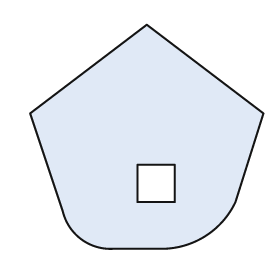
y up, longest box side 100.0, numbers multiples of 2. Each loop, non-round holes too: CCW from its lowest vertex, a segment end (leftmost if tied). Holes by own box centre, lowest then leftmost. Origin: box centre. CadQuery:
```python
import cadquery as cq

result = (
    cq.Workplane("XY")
    .moveTo(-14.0, -48.0)
    .lineTo(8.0, -48.0)
    .threePointArc((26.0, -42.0), (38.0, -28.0))
    .lineTo(50.0, 10.0)
    .lineTo(0.0, 48.0)
    .lineTo(-50.0, 10.0)
    .lineTo(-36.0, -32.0)
    .threePointArc((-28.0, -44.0), (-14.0, -48.0))
    .close()
    .moveTo(-4.0, -28.0)
    .lineTo(12.0, -28.0)
    .lineTo(12.0, -12.0)
    .lineTo(-4.0, -12.0)
    .close()
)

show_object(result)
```